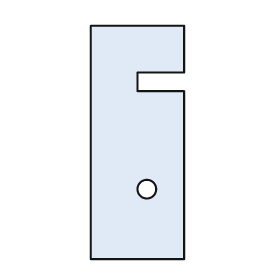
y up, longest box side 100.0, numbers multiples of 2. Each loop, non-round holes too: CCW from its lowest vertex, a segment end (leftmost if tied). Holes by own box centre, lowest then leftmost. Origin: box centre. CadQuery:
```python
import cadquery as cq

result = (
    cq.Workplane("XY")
    .moveTo(-20.0, -50.0)
    .lineTo(20.0, -50.0)
    .lineTo(20.0, 22.0)
    .lineTo(0.0, 22.0)
    .lineTo(0.0, 30.0)
    .lineTo(20.0, 30.0)
    .lineTo(20.0, 50.0)
    .lineTo(-20.0, 50.0)
    .close()
    .moveTo(4.0, -20.0)
    .circle(4.0)
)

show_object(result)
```